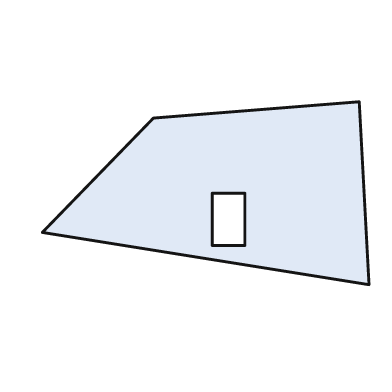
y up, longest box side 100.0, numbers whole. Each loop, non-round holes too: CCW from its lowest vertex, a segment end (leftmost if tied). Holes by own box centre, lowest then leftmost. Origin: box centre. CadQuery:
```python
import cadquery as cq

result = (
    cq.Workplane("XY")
    .moveTo(50.0, -28.0)
    .lineTo(47.0, 28.0)
    .lineTo(-16.0, 23.0)
    .lineTo(-50.0, -12.0)
    .close()
    .moveTo(2.0, -16.0)
    .lineTo(12.0, -16.0)
    .lineTo(12.0, 0.0)
    .lineTo(2.0, 0.0)
    .close()
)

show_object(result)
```